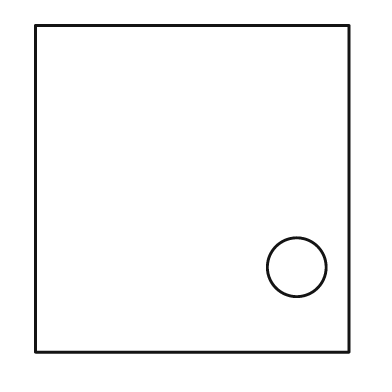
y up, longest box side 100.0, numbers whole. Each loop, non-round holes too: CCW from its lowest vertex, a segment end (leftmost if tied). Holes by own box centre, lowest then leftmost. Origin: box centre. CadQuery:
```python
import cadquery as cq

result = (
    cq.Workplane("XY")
    .moveTo(-48.0, -50.0)
    .lineTo(48.0, -50.0)
    .lineTo(48.0, 50.0)
    .lineTo(-48.0, 50.0)
    .close()
    .moveTo(32.0, -24.0)
    .circle(9.0)
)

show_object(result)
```